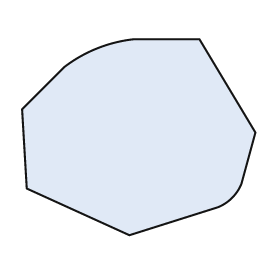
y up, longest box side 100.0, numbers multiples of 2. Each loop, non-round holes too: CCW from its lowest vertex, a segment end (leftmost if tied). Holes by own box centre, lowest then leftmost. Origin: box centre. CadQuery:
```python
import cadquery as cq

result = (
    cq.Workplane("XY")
    .moveTo(-4.0, -42.0)
    .lineTo(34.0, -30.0)
    .threePointArc((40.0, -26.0), (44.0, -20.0))
    .lineTo(50.0, 2.0)
    .lineTo(26.0, 42.0)
    .lineTo(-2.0, 42.0)
    .threePointArc((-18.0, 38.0), (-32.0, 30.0))
    .lineTo(-50.0, 12.0)
    .lineTo(-48.0, -22.0)
    .close()
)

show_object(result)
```